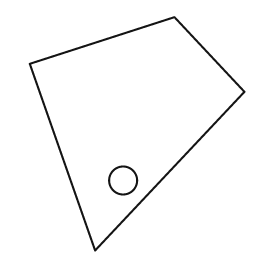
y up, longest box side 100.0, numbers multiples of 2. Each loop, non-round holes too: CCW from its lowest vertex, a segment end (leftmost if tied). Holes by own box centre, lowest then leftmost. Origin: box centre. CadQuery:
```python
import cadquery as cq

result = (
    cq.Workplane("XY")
    .moveTo(-18.0, -50.0)
    .lineTo(46.0, 18.0)
    .lineTo(16.0, 50.0)
    .lineTo(-46.0, 30.0)
    .close()
    .moveTo(-6.0, -20.0)
    .circle(6.0)
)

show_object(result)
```